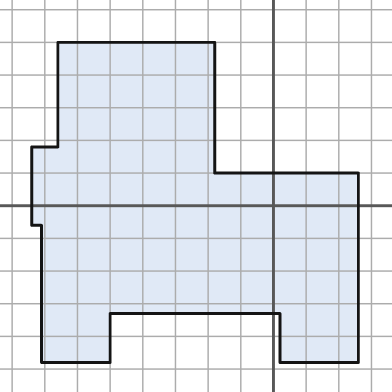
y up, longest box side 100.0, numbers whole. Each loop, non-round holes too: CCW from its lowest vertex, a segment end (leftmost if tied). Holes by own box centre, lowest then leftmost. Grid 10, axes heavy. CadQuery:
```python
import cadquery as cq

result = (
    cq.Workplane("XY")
    .moveTo(-71.0, -48.0)
    .lineTo(-50.0, -48.0)
    .lineTo(-50.0, -33.0)
    .lineTo(2.0, -33.0)
    .lineTo(2.0, -48.0)
    .lineTo(26.0, -48.0)
    .lineTo(26.0, 10.0)
    .lineTo(-18.0, 10.0)
    .lineTo(-18.0, 50.0)
    .lineTo(-66.0, 50.0)
    .lineTo(-66.0, 18.0)
    .lineTo(-74.0, 18.0)
    .lineTo(-74.0, -6.0)
    .lineTo(-71.0, -6.0)
    .close()
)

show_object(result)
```